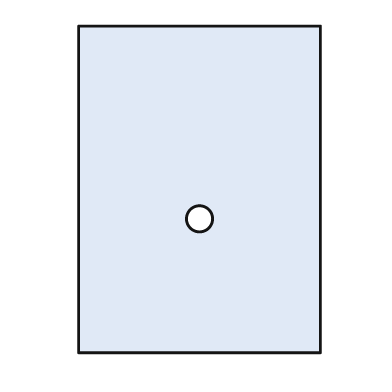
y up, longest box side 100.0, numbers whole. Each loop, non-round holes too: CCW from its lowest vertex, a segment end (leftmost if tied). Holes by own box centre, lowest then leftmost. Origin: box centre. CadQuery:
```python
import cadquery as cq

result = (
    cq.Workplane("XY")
    .moveTo(-37.0, -50.0)
    .lineTo(37.0, -50.0)
    .lineTo(37.0, 50.0)
    .lineTo(-37.0, 50.0)
    .close()
    .moveTo(0.0, -9.0)
    .circle(4.0)
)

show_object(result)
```